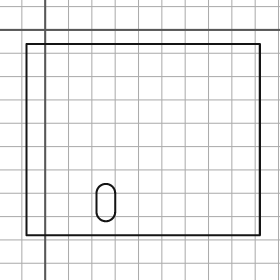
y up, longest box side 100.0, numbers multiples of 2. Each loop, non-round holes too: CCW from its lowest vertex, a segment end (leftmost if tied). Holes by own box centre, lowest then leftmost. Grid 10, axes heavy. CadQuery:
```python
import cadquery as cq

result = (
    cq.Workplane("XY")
    .moveTo(-8.0, -88.0)
    .lineTo(92.0, -88.0)
    .lineTo(92.0, -6.0)
    .lineTo(-8.0, -6.0)
    .close()
    .moveTo(22.0, -78.0)
    .threePointArc((26.0, -82.0), (30.0, -78.0))
    .lineTo(30.0, -70.0)
    .threePointArc((26.0, -66.0), (22.0, -70.0))
    .close()
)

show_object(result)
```